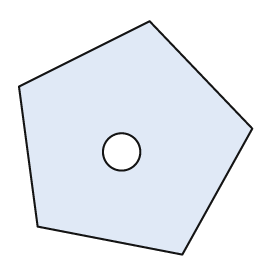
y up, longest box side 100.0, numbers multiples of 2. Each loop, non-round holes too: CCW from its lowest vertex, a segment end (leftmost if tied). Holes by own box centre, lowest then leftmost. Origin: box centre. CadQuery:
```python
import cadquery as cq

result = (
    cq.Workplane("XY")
    .moveTo(20.0, -50.0)
    .lineTo(50.0, 4.0)
    .lineTo(6.0, 50.0)
    .lineTo(-50.0, 22.0)
    .lineTo(-42.0, -38.0)
    .close()
    .moveTo(-6.0, -6.0)
    .circle(8.0)
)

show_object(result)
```